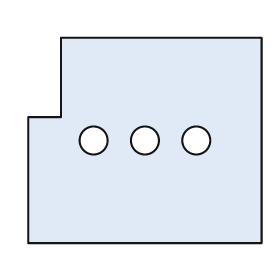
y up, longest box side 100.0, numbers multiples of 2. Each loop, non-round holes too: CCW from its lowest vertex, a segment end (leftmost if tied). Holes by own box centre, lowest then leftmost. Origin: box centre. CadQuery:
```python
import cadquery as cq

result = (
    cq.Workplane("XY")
    .moveTo(-50.0, -44.0)
    .lineTo(50.0, -44.0)
    .lineTo(50.0, 44.0)
    .lineTo(-36.0, 44.0)
    .lineTo(-36.0, 10.0)
    .lineTo(-50.0, 10.0)
    .close()
    .moveTo(-22.0, 0.0)
    .circle(6.0)
    .moveTo(0.0, 0.0)
    .circle(6.0)
    .moveTo(22.0, 0.0)
    .circle(6.0)
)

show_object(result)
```